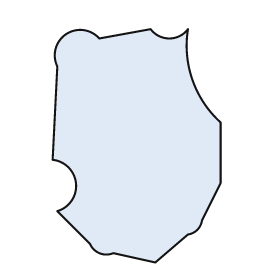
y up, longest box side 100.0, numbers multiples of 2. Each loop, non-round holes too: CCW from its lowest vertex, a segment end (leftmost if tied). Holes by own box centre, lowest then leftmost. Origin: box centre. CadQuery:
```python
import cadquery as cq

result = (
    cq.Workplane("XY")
    .moveTo(8.0, -50.0)
    .lineTo(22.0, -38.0)
    .threePointArc((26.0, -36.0), (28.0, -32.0))
    .lineTo(36.0, -16.0)
    .lineTo(36.0, 10.0)
    .threePointArc((24.0, 28.0), (22.0, 50.0))
    .threePointArc((14.0, 46.0), (6.0, 50.0))
    .lineTo(-16.0, 46.0)
    .threePointArc((-30.0, 48.0), (-34.0, 34.0))
    .lineTo(-36.0, -6.0)
    .threePointArc((-26.0, -16.0), (-34.0, -28.0))
    .lineTo(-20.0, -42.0)
    .threePointArc((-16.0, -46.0), (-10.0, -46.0))
    .close()
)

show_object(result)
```